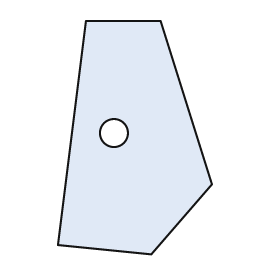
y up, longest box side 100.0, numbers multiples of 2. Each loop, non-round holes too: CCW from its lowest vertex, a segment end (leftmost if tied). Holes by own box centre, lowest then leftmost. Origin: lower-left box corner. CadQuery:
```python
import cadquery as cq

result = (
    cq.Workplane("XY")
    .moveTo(40.0, 0.0)
    .lineTo(66.0, 30.0)
    .lineTo(44.0, 100.0)
    .lineTo(12.0, 100.0)
    .lineTo(0.0, 4.0)
    .close()
    .moveTo(24.0, 52.0)
    .circle(6.0)
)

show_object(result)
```